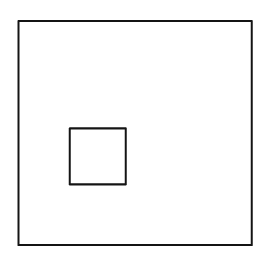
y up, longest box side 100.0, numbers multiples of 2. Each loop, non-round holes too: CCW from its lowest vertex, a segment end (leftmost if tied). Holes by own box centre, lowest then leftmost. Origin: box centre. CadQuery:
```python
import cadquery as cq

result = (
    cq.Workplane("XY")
    .moveTo(-50.0, -48.0)
    .lineTo(50.0, -48.0)
    .lineTo(50.0, 48.0)
    .lineTo(-50.0, 48.0)
    .close()
    .moveTo(-28.0, -22.0)
    .lineTo(-4.0, -22.0)
    .lineTo(-4.0, 2.0)
    .lineTo(-28.0, 2.0)
    .close()
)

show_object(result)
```